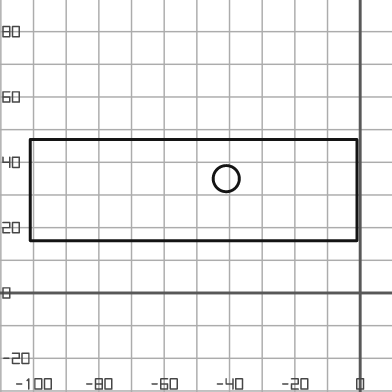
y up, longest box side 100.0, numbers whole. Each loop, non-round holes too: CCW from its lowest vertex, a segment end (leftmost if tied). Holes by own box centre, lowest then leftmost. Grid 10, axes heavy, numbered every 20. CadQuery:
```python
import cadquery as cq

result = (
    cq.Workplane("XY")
    .moveTo(-101.0, 16.0)
    .lineTo(-1.0, 16.0)
    .lineTo(-1.0, 47.0)
    .lineTo(-101.0, 47.0)
    .close()
    .moveTo(-41.0, 35.0)
    .circle(4.0)
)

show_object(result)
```